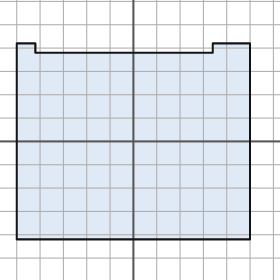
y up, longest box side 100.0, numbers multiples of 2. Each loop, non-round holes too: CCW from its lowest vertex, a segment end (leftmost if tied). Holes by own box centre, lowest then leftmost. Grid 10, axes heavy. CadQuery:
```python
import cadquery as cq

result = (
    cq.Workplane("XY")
    .moveTo(-50.0, -42.0)
    .lineTo(50.0, -42.0)
    .lineTo(50.0, 42.0)
    .lineTo(34.0, 42.0)
    .lineTo(34.0, 38.0)
    .lineTo(-42.0, 38.0)
    .lineTo(-42.0, 42.0)
    .lineTo(-50.0, 42.0)
    .close()
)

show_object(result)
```